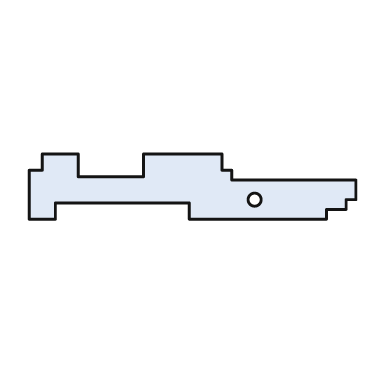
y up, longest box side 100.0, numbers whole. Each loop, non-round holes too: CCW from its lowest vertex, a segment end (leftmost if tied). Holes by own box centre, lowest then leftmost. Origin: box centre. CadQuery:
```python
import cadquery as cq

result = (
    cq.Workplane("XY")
    .moveTo(-50.0, -10.0)
    .lineTo(-42.0, -10.0)
    .lineTo(-42.0, -5.0)
    .lineTo(-1.0, -5.0)
    .lineTo(-1.0, -10.0)
    .lineTo(41.0, -10.0)
    .lineTo(41.0, -7.0)
    .lineTo(47.0, -7.0)
    .lineTo(47.0, -4.0)
    .lineTo(50.0, -4.0)
    .lineTo(50.0, 2.0)
    .lineTo(12.0, 2.0)
    .lineTo(12.0, 5.0)
    .lineTo(9.0, 5.0)
    .lineTo(9.0, 10.0)
    .lineTo(-15.0, 10.0)
    .lineTo(-15.0, 3.0)
    .lineTo(-35.0, 3.0)
    .lineTo(-35.0, 10.0)
    .lineTo(-46.0, 10.0)
    .lineTo(-46.0, 5.0)
    .lineTo(-50.0, 5.0)
    .close()
    .moveTo(19.0, -4.0)
    .circle(2.0)
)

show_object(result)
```